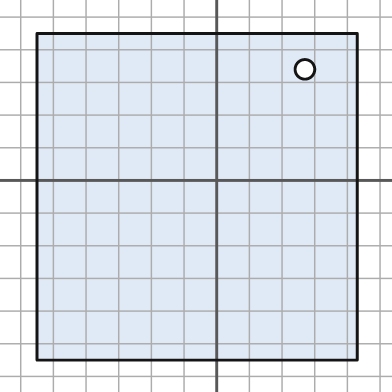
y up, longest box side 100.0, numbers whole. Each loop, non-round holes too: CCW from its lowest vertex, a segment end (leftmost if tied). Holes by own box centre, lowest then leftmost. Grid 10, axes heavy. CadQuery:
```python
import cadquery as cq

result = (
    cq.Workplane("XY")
    .moveTo(-55.0, -55.0)
    .lineTo(43.0, -55.0)
    .lineTo(43.0, 45.0)
    .lineTo(-55.0, 45.0)
    .close()
    .moveTo(27.0, 34.0)
    .circle(3.0)
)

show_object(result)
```